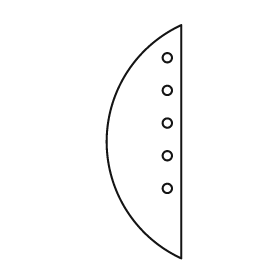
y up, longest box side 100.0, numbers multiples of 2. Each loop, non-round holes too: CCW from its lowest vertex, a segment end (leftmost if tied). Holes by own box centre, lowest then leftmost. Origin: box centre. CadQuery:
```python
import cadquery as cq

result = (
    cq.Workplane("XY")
    .moveTo(16.0, -50.0)
    .lineTo(16.0, 50.0)
    .threePointArc((-16.0, 0.0), (16.0, -50.0))
    .close()
    .moveTo(10.0, -20.0)
    .circle(2.0)
    .moveTo(10.0, -6.0)
    .circle(2.0)
    .moveTo(10.0, 8.0)
    .circle(2.0)
    .moveTo(10.0, 22.0)
    .circle(2.0)
    .moveTo(10.0, 36.0)
    .circle(2.0)
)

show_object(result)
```